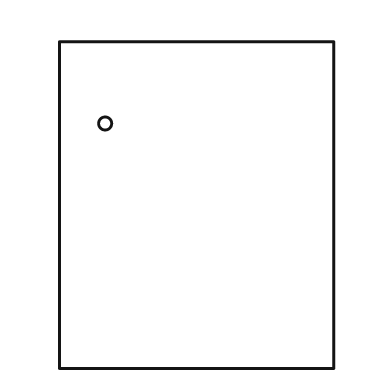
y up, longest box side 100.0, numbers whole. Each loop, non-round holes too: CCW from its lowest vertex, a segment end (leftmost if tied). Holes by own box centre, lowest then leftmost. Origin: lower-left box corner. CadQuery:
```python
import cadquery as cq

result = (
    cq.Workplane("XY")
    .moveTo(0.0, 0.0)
    .lineTo(84.0, 0.0)
    .lineTo(84.0, 100.0)
    .lineTo(0.0, 100.0)
    .close()
    .moveTo(14.0, 75.0)
    .circle(2.0)
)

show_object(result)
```